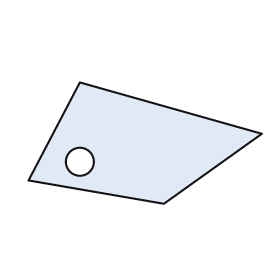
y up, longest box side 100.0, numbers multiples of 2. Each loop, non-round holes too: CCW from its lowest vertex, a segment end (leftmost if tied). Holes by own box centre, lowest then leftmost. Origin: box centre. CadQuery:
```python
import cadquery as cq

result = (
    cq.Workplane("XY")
    .moveTo(8.0, -26.0)
    .lineTo(50.0, 4.0)
    .lineTo(-28.0, 26.0)
    .lineTo(-50.0, -16.0)
    .close()
    .moveTo(-28.0, -8.0)
    .circle(6.0)
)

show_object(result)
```